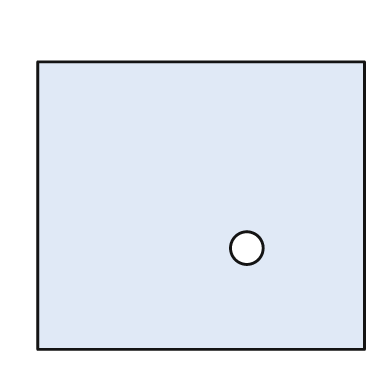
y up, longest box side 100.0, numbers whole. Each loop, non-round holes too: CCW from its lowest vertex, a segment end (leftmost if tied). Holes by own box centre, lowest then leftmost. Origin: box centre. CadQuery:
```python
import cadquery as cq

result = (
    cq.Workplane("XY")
    .moveTo(-50.0, -44.0)
    .lineTo(50.0, -44.0)
    .lineTo(50.0, 44.0)
    .lineTo(-50.0, 44.0)
    .close()
    .moveTo(14.0, -13.0)
    .circle(5.0)
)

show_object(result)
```